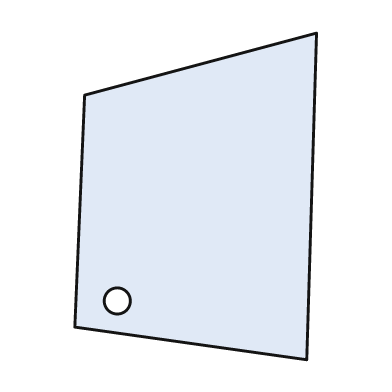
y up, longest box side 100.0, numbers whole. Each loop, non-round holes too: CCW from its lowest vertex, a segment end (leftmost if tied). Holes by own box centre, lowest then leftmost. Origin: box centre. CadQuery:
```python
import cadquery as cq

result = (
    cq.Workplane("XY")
    .moveTo(34.0, -50.0)
    .lineTo(37.0, 50.0)
    .lineTo(-34.0, 31.0)
    .lineTo(-37.0, -40.0)
    .close()
    .moveTo(-24.0, -32.0)
    .circle(4.0)
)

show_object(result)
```